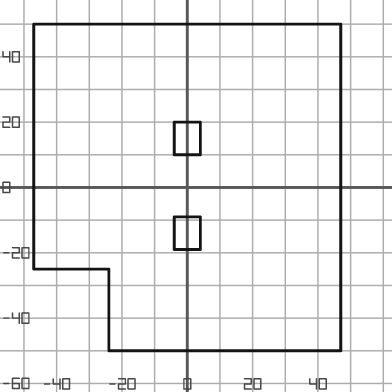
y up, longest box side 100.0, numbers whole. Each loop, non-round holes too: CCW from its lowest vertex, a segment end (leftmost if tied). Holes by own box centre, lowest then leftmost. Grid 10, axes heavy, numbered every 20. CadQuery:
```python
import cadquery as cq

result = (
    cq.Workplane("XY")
    .moveTo(-24.0, -50.0)
    .lineTo(47.0, -50.0)
    .lineTo(47.0, 50.0)
    .lineTo(-47.0, 50.0)
    .lineTo(-47.0, -25.0)
    .lineTo(-24.0, -25.0)
    .close()
    .moveTo(-4.0, -19.0)
    .lineTo(4.0, -19.0)
    .lineTo(4.0, -9.0)
    .lineTo(-4.0, -9.0)
    .close()
    .moveTo(-4.0, 10.0)
    .lineTo(4.0, 10.0)
    .lineTo(4.0, 20.0)
    .lineTo(-4.0, 20.0)
    .close()
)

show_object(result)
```